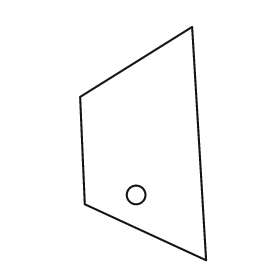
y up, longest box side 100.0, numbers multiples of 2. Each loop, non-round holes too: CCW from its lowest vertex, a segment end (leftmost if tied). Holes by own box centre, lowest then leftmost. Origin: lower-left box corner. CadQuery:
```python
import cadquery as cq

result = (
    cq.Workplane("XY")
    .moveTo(54.0, 0.0)
    .lineTo(48.0, 100.0)
    .lineTo(0.0, 70.0)
    .lineTo(2.0, 24.0)
    .close()
    .moveTo(24.0, 28.0)
    .circle(4.0)
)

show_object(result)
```